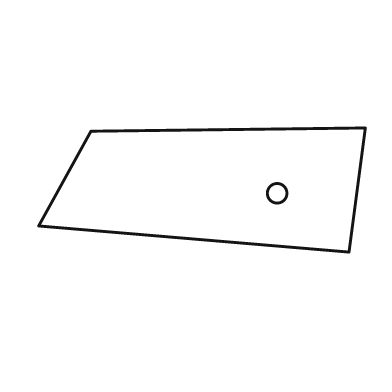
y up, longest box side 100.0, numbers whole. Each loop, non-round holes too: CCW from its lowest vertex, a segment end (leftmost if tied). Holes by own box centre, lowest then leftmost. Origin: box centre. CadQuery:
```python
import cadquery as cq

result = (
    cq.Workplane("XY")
    .moveTo(45.0, -19.0)
    .lineTo(50.0, 19.0)
    .lineTo(-34.0, 18.0)
    .lineTo(-50.0, -11.0)
    .close()
    .moveTo(23.0, -1.0)
    .circle(3.0)
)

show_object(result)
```